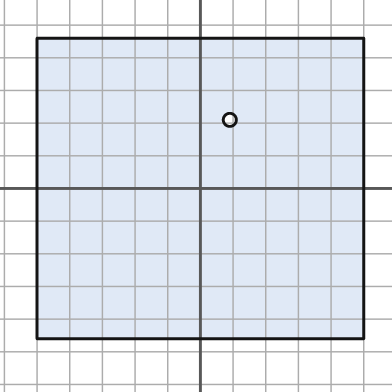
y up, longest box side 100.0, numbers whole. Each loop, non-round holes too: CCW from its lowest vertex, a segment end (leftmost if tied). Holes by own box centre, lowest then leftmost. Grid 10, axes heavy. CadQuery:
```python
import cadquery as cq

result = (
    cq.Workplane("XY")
    .moveTo(-50.0, -46.0)
    .lineTo(50.0, -46.0)
    .lineTo(50.0, 46.0)
    .lineTo(-50.0, 46.0)
    .close()
    .moveTo(9.0, 21.0)
    .circle(2.0)
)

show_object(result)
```